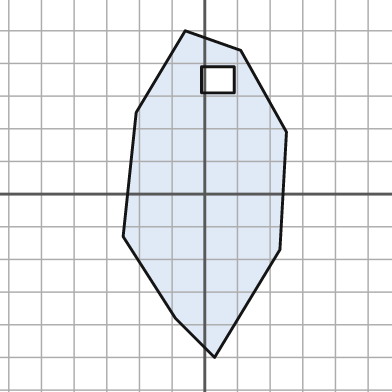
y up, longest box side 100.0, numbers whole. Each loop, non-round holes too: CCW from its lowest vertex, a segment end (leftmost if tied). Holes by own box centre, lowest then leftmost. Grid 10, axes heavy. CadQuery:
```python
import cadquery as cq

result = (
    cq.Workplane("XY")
    .moveTo(3.0, -50.0)
    .lineTo(23.0, -17.0)
    .lineTo(25.0, 19.0)
    .lineTo(11.0, 44.0)
    .lineTo(-6.0, 50.0)
    .lineTo(-21.0, 25.0)
    .lineTo(-25.0, -13.0)
    .lineTo(-9.0, -38.0)
    .close()
    .moveTo(-1.0, 31.0)
    .lineTo(9.0, 31.0)
    .lineTo(9.0, 39.0)
    .lineTo(-1.0, 39.0)
    .close()
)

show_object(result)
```